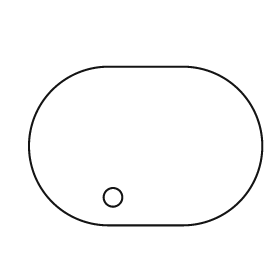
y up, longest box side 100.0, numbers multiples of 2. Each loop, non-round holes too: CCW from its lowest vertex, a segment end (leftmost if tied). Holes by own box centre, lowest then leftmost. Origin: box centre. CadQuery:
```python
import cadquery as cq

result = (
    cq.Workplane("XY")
    .moveTo(-16.0, -34.0)
    .lineTo(16.0, -34.0)
    .threePointArc((50.0, 0.0), (16.0, 34.0))
    .lineTo(-16.0, 34.0)
    .threePointArc((-50.0, 0.0), (-16.0, -34.0))
    .close()
    .moveTo(-14.0, -22.0)
    .circle(4.0)
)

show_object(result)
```